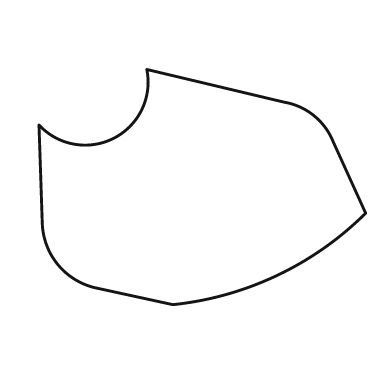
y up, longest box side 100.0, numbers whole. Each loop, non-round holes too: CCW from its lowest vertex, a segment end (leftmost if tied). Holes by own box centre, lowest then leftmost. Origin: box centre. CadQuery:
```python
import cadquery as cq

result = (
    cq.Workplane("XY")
    .moveTo(-9.0, -36.0)
    .threePointArc((23.0, -27.0), (50.0, -8.0))
    .lineTo(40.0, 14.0)
    .threePointArc((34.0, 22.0), (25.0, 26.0))
    .lineTo(-17.0, 36.0)
    .threePointArc((-27.0, 15.0), (-50.0, 19.0))
    .lineTo(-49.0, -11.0)
    .threePointArc((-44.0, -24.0), (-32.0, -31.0))
    .close()
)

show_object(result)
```